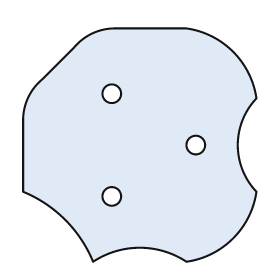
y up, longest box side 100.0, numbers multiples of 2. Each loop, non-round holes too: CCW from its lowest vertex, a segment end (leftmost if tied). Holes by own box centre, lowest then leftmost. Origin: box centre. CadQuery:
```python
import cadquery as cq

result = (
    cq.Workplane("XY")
    .moveTo(-20.0, -50.0)
    .threePointArc((0.0, -44.0), (20.0, -50.0))
    .threePointArc((40.0, -40.0), (50.0, -20.0))
    .threePointArc((42.0, 0.0), (50.0, 20.0))
    .threePointArc((40.0, 40.0), (20.0, 50.0))
    .lineTo(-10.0, 50.0)
    .threePointArc((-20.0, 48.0), (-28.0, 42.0))
    .lineTo(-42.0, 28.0)
    .threePointArc((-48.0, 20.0), (-50.0, 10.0))
    .lineTo(-50.0, -20.0)
    .threePointArc((-32.0, -32.0), (-20.0, -50.0))
    .close()
    .moveTo(-12.0, -22.0)
    .circle(4.0)
    .moveTo(24.0, 0.0)
    .circle(4.0)
    .moveTo(-12.0, 22.0)
    .circle(4.0)
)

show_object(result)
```